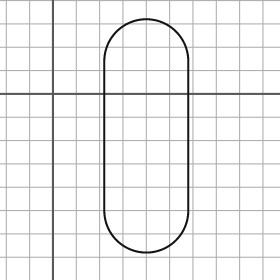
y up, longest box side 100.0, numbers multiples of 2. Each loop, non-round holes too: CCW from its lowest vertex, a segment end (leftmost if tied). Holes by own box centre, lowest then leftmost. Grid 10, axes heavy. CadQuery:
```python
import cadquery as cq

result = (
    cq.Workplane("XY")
    .moveTo(22.0, -50.0)
    .threePointArc((40.0, -68.0), (58.0, -50.0))
    .lineTo(58.0, 14.0)
    .threePointArc((40.0, 32.0), (22.0, 14.0))
    .close()
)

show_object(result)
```